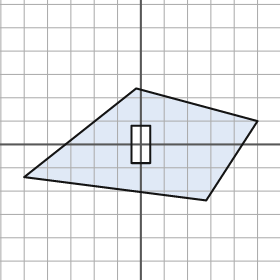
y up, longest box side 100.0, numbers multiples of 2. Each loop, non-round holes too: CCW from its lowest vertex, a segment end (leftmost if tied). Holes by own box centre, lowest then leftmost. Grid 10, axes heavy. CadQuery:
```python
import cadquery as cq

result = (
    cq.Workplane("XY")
    .moveTo(28.0, -24.0)
    .lineTo(50.0, 10.0)
    .lineTo(-2.0, 24.0)
    .lineTo(-50.0, -14.0)
    .close()
    .moveTo(-4.0, -8.0)
    .lineTo(4.0, -8.0)
    .lineTo(4.0, 8.0)
    .lineTo(-4.0, 8.0)
    .close()
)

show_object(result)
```